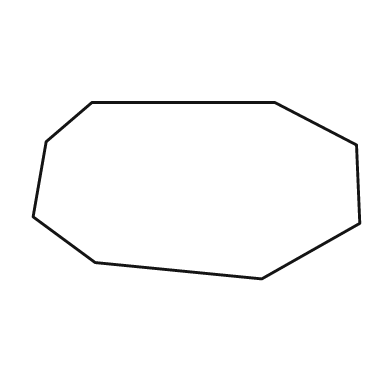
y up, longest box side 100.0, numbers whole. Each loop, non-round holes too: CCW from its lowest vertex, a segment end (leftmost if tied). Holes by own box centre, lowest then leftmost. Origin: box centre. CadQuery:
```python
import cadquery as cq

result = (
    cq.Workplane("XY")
    .moveTo(20.0, -27.0)
    .lineTo(50.0, -10.0)
    .lineTo(49.0, 14.0)
    .lineTo(24.0, 27.0)
    .lineTo(-32.0, 27.0)
    .lineTo(-46.0, 15.0)
    .lineTo(-50.0, -8.0)
    .lineTo(-31.0, -22.0)
    .close()
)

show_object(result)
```